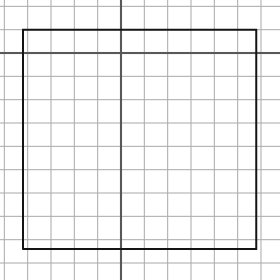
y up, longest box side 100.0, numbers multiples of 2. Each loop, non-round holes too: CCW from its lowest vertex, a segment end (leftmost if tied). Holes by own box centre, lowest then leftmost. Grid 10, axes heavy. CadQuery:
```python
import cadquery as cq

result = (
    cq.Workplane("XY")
    .moveTo(-42.0, -84.0)
    .lineTo(58.0, -84.0)
    .lineTo(58.0, 10.0)
    .lineTo(-42.0, 10.0)
    .close()
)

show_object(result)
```